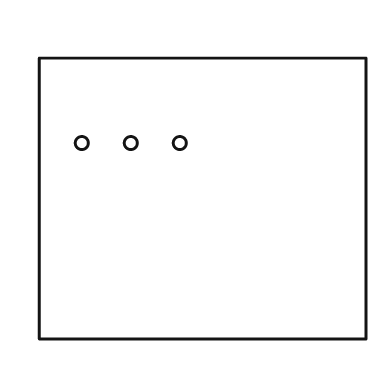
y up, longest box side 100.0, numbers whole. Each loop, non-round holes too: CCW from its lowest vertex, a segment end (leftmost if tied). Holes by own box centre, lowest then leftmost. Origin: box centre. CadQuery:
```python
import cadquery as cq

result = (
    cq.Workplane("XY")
    .moveTo(-50.0, -43.0)
    .lineTo(50.0, -43.0)
    .lineTo(50.0, 43.0)
    .lineTo(-50.0, 43.0)
    .close()
    .moveTo(-37.0, 17.0)
    .circle(2.0)
    .moveTo(-22.0, 17.0)
    .circle(2.0)
    .moveTo(-7.0, 17.0)
    .circle(2.0)
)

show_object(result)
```